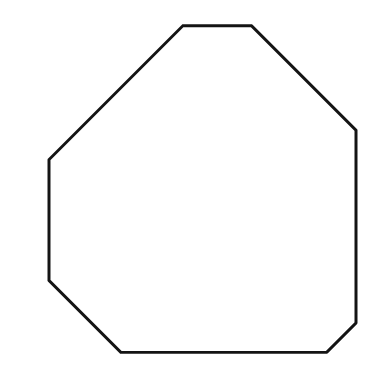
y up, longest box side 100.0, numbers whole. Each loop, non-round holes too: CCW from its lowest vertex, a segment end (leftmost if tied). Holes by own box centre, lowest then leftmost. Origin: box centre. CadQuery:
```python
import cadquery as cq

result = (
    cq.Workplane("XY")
    .moveTo(-25.0, -50.0)
    .lineTo(38.0, -50.0)
    .lineTo(47.0, -41.0)
    .lineTo(47.0, 18.0)
    .lineTo(15.0, 50.0)
    .lineTo(-6.0, 50.0)
    .lineTo(-47.0, 9.0)
    .lineTo(-47.0, -28.0)
    .close()
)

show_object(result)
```